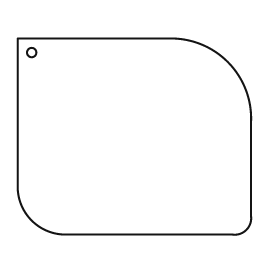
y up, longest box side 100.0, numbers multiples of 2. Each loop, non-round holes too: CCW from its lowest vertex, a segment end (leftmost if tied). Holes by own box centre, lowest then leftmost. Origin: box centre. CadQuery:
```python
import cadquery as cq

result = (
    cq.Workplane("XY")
    .moveTo(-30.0, -42.0)
    .lineTo(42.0, -42.0)
    .threePointArc((48.0, -40.0), (50.0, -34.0))
    .lineTo(50.0, 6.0)
    .threePointArc((40.0, 32.0), (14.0, 42.0))
    .lineTo(-50.0, 42.0)
    .lineTo(-50.0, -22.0)
    .threePointArc((-44.0, -36.0), (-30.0, -42.0))
    .close()
    .moveTo(-44.0, 36.0)
    .circle(2.0)
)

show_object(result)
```